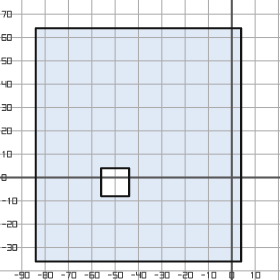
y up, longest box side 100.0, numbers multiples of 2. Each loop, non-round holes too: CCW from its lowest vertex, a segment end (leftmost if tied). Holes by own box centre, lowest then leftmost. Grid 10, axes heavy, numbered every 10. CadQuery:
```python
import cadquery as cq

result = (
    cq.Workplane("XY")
    .moveTo(-84.0, -36.0)
    .lineTo(4.0, -36.0)
    .lineTo(4.0, 64.0)
    .lineTo(-84.0, 64.0)
    .close()
    .moveTo(-56.0, -8.0)
    .lineTo(-44.0, -8.0)
    .lineTo(-44.0, 4.0)
    .lineTo(-56.0, 4.0)
    .close()
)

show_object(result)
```